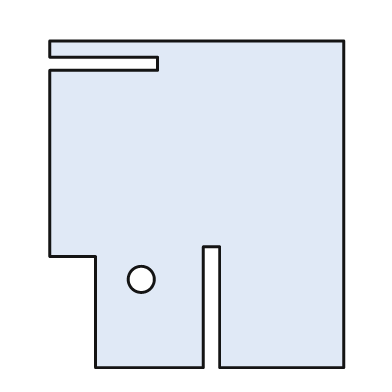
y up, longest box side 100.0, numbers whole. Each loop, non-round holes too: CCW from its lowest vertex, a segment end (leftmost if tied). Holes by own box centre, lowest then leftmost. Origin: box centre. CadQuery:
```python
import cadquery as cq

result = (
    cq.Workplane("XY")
    .moveTo(-31.0, -50.0)
    .lineTo(2.0, -50.0)
    .lineTo(2.0, -13.0)
    .lineTo(7.0, -13.0)
    .lineTo(7.0, -50.0)
    .lineTo(45.0, -50.0)
    .lineTo(45.0, 50.0)
    .lineTo(-45.0, 50.0)
    .lineTo(-45.0, 45.0)
    .lineTo(-12.0, 45.0)
    .lineTo(-12.0, 41.0)
    .lineTo(-45.0, 41.0)
    .lineTo(-45.0, -16.0)
    .lineTo(-31.0, -16.0)
    .close()
    .moveTo(-17.0, -23.0)
    .circle(4.0)
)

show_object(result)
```